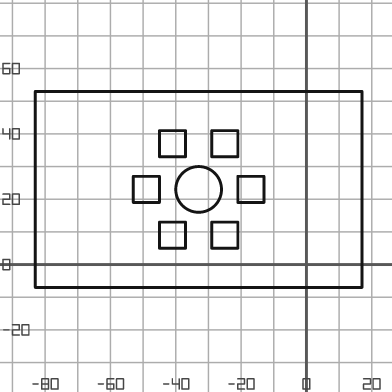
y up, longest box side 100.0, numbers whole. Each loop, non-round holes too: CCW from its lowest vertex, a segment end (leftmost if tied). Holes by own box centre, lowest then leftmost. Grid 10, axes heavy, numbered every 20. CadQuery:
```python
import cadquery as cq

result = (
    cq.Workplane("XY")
    .moveTo(-83.0, -7.0)
    .lineTo(17.0, -7.0)
    .lineTo(17.0, 53.0)
    .lineTo(-83.0, 53.0)
    .close()
    .moveTo(-45.0, 5.0)
    .lineTo(-37.0, 5.0)
    .lineTo(-37.0, 13.0)
    .lineTo(-45.0, 13.0)
    .close()
    .moveTo(-29.0, 5.0)
    .lineTo(-21.0, 5.0)
    .lineTo(-21.0, 13.0)
    .lineTo(-29.0, 13.0)
    .close()
    .moveTo(-53.0, 19.0)
    .lineTo(-45.0, 19.0)
    .lineTo(-45.0, 27.0)
    .lineTo(-53.0, 27.0)
    .close()
    .moveTo(-33.0, 23.0)
    .circle(7.0)
    .moveTo(-21.0, 19.0)
    .lineTo(-13.0, 19.0)
    .lineTo(-13.0, 27.0)
    .lineTo(-21.0, 27.0)
    .close()
    .moveTo(-45.0, 33.0)
    .lineTo(-37.0, 33.0)
    .lineTo(-37.0, 41.0)
    .lineTo(-45.0, 41.0)
    .close()
    .moveTo(-29.0, 33.0)
    .lineTo(-21.0, 33.0)
    .lineTo(-21.0, 41.0)
    .lineTo(-29.0, 41.0)
    .close()
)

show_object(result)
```